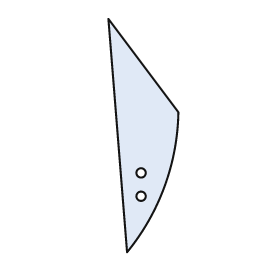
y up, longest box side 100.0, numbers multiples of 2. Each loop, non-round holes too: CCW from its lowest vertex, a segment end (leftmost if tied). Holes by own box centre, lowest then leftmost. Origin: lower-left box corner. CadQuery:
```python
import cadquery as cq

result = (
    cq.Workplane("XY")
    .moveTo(8.0, 0.0)
    .threePointArc((24.0, 28.0), (30.0, 60.0))
    .lineTo(0.0, 100.0)
    .close()
    .moveTo(14.0, 24.0)
    .circle(2.0)
    .moveTo(14.0, 34.0)
    .circle(2.0)
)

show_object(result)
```